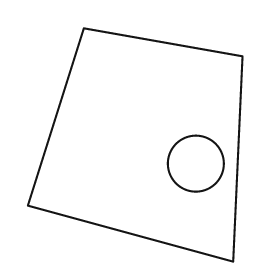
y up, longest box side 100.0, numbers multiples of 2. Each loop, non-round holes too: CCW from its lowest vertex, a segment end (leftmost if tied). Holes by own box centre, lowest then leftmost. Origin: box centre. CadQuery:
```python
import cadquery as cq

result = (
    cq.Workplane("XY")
    .moveTo(42.0, -50.0)
    .lineTo(46.0, 38.0)
    .lineTo(-22.0, 50.0)
    .lineTo(-46.0, -26.0)
    .close()
    .moveTo(26.0, -8.0)
    .circle(12.0)
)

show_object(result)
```